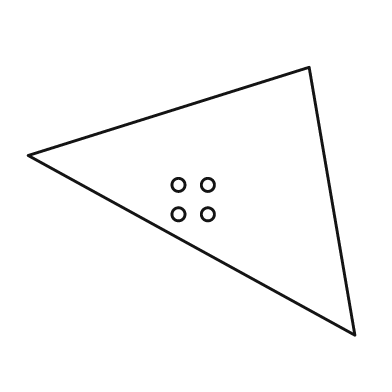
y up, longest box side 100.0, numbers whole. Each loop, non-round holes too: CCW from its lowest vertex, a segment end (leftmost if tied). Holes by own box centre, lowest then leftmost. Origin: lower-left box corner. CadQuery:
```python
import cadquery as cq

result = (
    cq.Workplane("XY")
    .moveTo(100.0, 0.0)
    .lineTo(86.0, 82.0)
    .lineTo(0.0, 55.0)
    .close()
    .moveTo(46.0, 37.0)
    .circle(2.0)
    .moveTo(55.0, 37.0)
    .circle(2.0)
    .moveTo(46.0, 46.0)
    .circle(2.0)
    .moveTo(55.0, 46.0)
    .circle(2.0)
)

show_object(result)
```